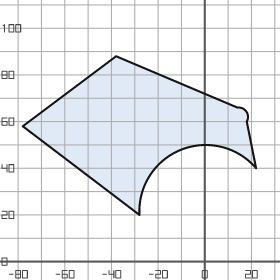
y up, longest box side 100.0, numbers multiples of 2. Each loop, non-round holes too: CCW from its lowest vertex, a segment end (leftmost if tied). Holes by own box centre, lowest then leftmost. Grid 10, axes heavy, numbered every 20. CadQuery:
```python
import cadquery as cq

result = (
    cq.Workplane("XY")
    .moveTo(-28.0, 20.0)
    .threePointArc((-10.0, 48.0), (22.0, 40.0))
    .lineTo(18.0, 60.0)
    .threePointArc((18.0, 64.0), (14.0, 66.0))
    .lineTo(-38.0, 88.0)
    .lineTo(-78.0, 58.0)
    .close()
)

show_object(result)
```